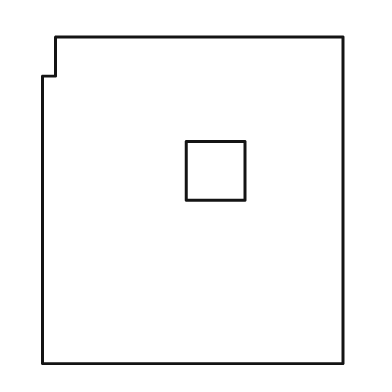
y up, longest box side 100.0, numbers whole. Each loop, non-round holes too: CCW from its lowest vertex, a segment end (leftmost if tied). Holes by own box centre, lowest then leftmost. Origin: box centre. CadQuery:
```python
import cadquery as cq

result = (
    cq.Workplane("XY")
    .moveTo(-46.0, -50.0)
    .lineTo(46.0, -50.0)
    .lineTo(46.0, 50.0)
    .lineTo(-42.0, 50.0)
    .lineTo(-42.0, 38.0)
    .lineTo(-46.0, 38.0)
    .close()
    .moveTo(-2.0, 0.0)
    .lineTo(16.0, 0.0)
    .lineTo(16.0, 18.0)
    .lineTo(-2.0, 18.0)
    .close()
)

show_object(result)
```